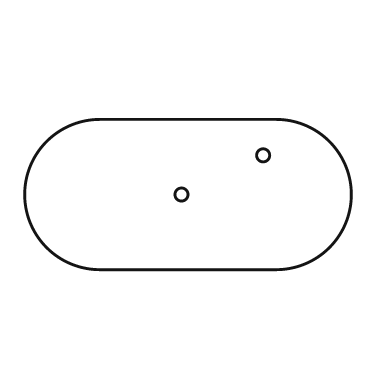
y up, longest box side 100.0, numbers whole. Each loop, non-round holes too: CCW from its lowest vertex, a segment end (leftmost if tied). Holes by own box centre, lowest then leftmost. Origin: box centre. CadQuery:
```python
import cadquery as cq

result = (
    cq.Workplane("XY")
    .moveTo(-27.0, -23.0)
    .lineTo(27.0, -23.0)
    .threePointArc((50.0, 0.0), (27.0, 23.0))
    .lineTo(-27.0, 23.0)
    .threePointArc((-50.0, 0.0), (-27.0, -23.0))
    .close()
    .moveTo(-2.0, 0.0)
    .circle(2.0)
    .moveTo(23.0, 12.0)
    .circle(2.0)
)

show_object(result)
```